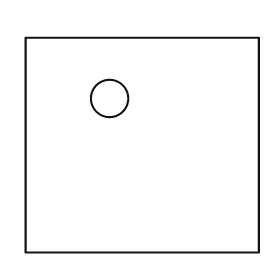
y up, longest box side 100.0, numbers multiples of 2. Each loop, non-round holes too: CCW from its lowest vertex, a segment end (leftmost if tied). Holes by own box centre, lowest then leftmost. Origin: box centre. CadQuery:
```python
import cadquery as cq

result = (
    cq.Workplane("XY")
    .moveTo(-50.0, -46.0)
    .lineTo(50.0, -46.0)
    .lineTo(50.0, 46.0)
    .lineTo(-50.0, 46.0)
    .close()
    .moveTo(-14.0, 20.0)
    .circle(8.0)
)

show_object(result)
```